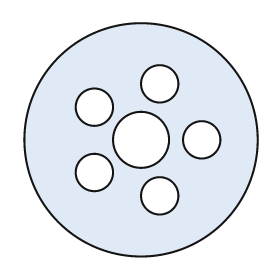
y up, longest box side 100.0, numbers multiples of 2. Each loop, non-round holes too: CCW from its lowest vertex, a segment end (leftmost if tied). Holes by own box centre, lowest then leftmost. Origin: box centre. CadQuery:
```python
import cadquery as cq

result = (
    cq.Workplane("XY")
    .moveTo(0.0, 0.0)
    .circle(50.0)
    .moveTo(8.0, -24.0)
    .circle(8.0)
    .moveTo(-20.0, -14.0)
    .circle(8.0)
    .moveTo(0.0, 0.0)
    .circle(12.0)
    .moveTo(26.0, 0.0)
    .circle(8.0)
    .moveTo(-20.0, 14.0)
    .circle(8.0)
    .moveTo(8.0, 24.0)
    .circle(8.0)
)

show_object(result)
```